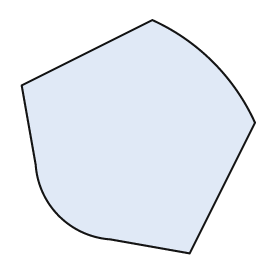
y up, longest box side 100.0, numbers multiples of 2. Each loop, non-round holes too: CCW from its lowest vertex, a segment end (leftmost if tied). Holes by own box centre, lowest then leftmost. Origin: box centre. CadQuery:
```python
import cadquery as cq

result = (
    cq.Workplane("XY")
    .moveTo(22.0, -50.0)
    .lineTo(50.0, 6.0)
    .threePointArc((32.0, 32.0), (6.0, 50.0))
    .lineTo(-50.0, 22.0)
    .lineTo(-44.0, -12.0)
    .threePointArc((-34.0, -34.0), (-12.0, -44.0))
    .close()
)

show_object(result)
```